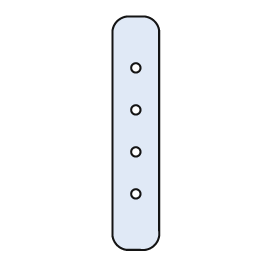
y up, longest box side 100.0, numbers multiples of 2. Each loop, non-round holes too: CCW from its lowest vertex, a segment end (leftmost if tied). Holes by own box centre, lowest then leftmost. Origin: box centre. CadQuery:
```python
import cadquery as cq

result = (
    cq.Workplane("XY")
    .moveTo(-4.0, -50.0)
    .lineTo(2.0, -50.0)
    .threePointArc((8.0, -48.0), (10.0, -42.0))
    .lineTo(10.0, 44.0)
    .threePointArc((8.0, 48.0), (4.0, 50.0))
    .lineTo(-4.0, 50.0)
    .threePointArc((-8.0, 48.0), (-10.0, 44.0))
    .lineTo(-10.0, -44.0)
    .threePointArc((-8.0, -48.0), (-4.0, -50.0))
    .close()
    .moveTo(0.0, -26.0)
    .circle(2.0)
    .moveTo(0.0, -8.0)
    .circle(2.0)
    .moveTo(0.0, 10.0)
    .circle(2.0)
    .moveTo(0.0, 28.0)
    .circle(2.0)
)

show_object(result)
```